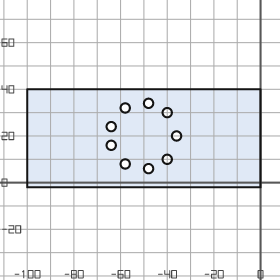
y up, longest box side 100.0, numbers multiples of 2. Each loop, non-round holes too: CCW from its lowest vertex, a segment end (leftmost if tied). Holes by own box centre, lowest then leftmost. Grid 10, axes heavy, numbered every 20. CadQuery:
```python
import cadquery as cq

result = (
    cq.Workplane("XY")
    .moveTo(-100.0, -2.0)
    .lineTo(0.0, -2.0)
    .lineTo(0.0, 40.0)
    .lineTo(-100.0, 40.0)
    .close()
    .moveTo(-48.0, 6.0)
    .circle(2.0)
    .moveTo(-58.0, 8.0)
    .circle(2.0)
    .moveTo(-40.0, 10.0)
    .circle(2.0)
    .moveTo(-64.0, 16.0)
    .circle(2.0)
    .moveTo(-36.0, 20.0)
    .circle(2.0)
    .moveTo(-64.0, 24.0)
    .circle(2.0)
    .moveTo(-40.0, 30.0)
    .circle(2.0)
    .moveTo(-58.0, 32.0)
    .circle(2.0)
    .moveTo(-48.0, 34.0)
    .circle(2.0)
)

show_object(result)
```